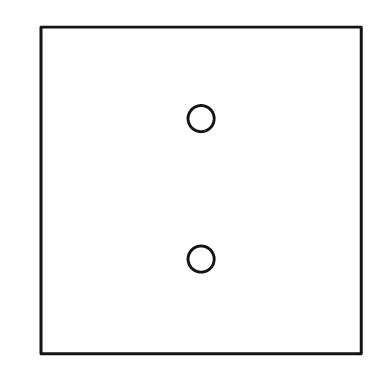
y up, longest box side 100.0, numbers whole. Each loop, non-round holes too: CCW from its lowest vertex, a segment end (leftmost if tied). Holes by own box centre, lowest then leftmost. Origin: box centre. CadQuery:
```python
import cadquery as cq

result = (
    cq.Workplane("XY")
    .moveTo(-49.0, -50.0)
    .lineTo(49.0, -50.0)
    .lineTo(49.0, 50.0)
    .lineTo(-49.0, 50.0)
    .close()
    .moveTo(0.0, -21.0)
    .circle(4.0)
    .moveTo(0.0, 22.0)
    .circle(4.0)
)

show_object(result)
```